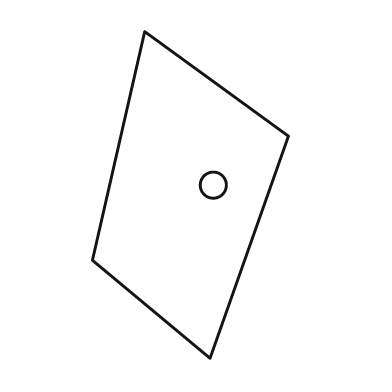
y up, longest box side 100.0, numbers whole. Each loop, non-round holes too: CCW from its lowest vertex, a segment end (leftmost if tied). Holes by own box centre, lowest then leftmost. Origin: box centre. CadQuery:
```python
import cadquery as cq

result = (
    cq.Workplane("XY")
    .moveTo(6.0, -50.0)
    .lineTo(30.0, 18.0)
    .lineTo(-14.0, 50.0)
    .lineTo(-30.0, -20.0)
    .close()
    .moveTo(7.0, 3.0)
    .circle(4.0)
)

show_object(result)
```